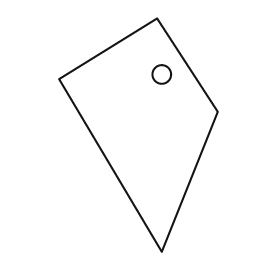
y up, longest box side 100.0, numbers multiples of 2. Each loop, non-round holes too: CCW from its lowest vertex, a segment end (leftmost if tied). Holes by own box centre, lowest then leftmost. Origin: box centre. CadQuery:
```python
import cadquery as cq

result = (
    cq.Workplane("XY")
    .moveTo(10.0, -50.0)
    .lineTo(34.0, 10.0)
    .lineTo(8.0, 50.0)
    .lineTo(-34.0, 24.0)
    .close()
    .moveTo(10.0, 26.0)
    .circle(4.0)
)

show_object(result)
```